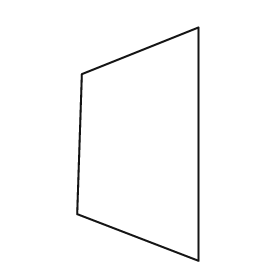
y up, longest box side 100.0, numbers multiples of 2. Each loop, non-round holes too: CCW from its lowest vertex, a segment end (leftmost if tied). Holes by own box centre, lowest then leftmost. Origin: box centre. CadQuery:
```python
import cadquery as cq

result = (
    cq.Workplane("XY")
    .moveTo(26.0, -50.0)
    .lineTo(26.0, 50.0)
    .lineTo(-24.0, 30.0)
    .lineTo(-26.0, -30.0)
    .close()
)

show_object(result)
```